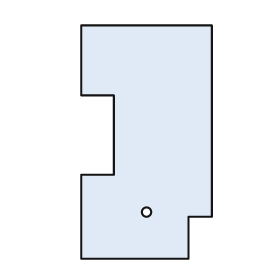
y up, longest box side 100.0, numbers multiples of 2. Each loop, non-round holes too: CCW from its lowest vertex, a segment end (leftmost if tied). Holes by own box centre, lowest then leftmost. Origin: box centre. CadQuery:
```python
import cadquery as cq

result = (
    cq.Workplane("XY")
    .moveTo(-28.0, -50.0)
    .lineTo(18.0, -50.0)
    .lineTo(18.0, -32.0)
    .lineTo(28.0, -32.0)
    .lineTo(28.0, 50.0)
    .lineTo(-28.0, 50.0)
    .lineTo(-28.0, 20.0)
    .lineTo(-14.0, 20.0)
    .lineTo(-14.0, -14.0)
    .lineTo(-28.0, -14.0)
    .close()
    .moveTo(0.0, -30.0)
    .circle(2.0)
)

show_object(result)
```